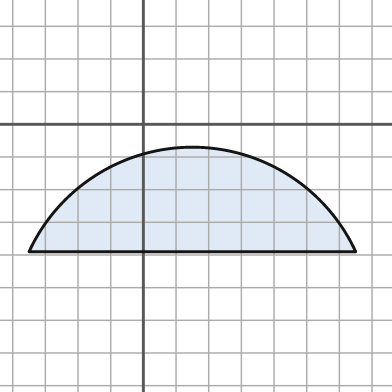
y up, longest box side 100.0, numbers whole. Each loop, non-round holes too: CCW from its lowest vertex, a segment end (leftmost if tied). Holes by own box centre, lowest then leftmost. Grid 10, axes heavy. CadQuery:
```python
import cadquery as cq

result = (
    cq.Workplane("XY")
    .moveTo(-35.0, -39.0)
    .lineTo(65.0, -39.0)
    .threePointArc((15.0, -7.0), (-35.0, -39.0))
    .close()
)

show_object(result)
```